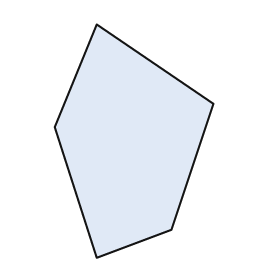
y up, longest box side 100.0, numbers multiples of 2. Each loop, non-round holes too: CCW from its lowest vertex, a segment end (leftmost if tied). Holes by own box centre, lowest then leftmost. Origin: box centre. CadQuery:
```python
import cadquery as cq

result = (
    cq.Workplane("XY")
    .moveTo(-16.0, -50.0)
    .lineTo(16.0, -38.0)
    .lineTo(34.0, 16.0)
    .lineTo(-16.0, 50.0)
    .lineTo(-34.0, 6.0)
    .close()
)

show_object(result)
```